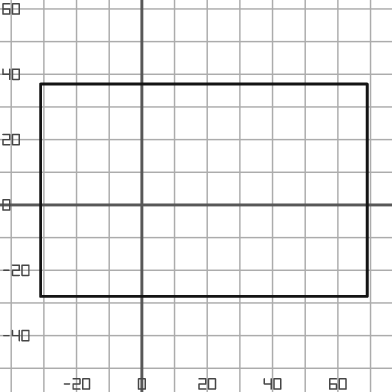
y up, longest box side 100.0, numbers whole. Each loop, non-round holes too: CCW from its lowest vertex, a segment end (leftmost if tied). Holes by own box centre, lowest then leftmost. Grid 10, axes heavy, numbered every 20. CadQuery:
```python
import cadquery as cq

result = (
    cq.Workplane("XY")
    .moveTo(-31.0, -28.0)
    .lineTo(69.0, -28.0)
    .lineTo(69.0, 37.0)
    .lineTo(-31.0, 37.0)
    .close()
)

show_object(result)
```